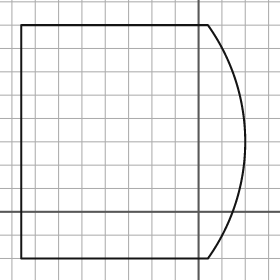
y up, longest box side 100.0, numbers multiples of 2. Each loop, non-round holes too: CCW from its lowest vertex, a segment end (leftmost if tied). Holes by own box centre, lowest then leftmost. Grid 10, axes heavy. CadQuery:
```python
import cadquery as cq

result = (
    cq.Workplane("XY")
    .moveTo(-76.0, -20.0)
    .lineTo(4.0, -20.0)
    .threePointArc((20.0, 30.0), (4.0, 80.0))
    .lineTo(-76.0, 80.0)
    .close()
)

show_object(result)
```